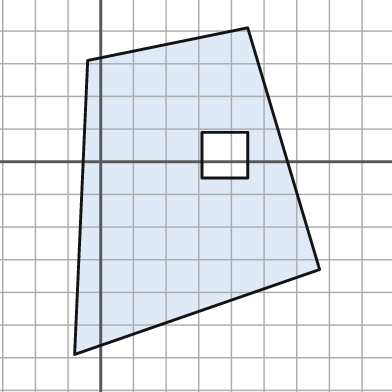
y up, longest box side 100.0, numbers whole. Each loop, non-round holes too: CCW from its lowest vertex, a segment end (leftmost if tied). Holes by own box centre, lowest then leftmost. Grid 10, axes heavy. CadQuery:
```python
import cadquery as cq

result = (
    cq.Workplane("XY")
    .moveTo(-8.0, -59.0)
    .lineTo(67.0, -33.0)
    .lineTo(45.0, 41.0)
    .lineTo(-4.0, 31.0)
    .close()
    .moveTo(31.0, -5.0)
    .lineTo(45.0, -5.0)
    .lineTo(45.0, 9.0)
    .lineTo(31.0, 9.0)
    .close()
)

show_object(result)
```